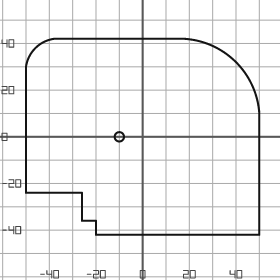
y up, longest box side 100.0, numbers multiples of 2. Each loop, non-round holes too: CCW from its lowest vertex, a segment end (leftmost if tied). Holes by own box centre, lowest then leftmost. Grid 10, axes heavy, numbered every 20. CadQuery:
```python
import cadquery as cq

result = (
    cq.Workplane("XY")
    .moveTo(-20.0, -42.0)
    .lineTo(50.0, -42.0)
    .lineTo(50.0, 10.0)
    .threePointArc((40.0, 32.0), (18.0, 42.0))
    .lineTo(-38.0, 42.0)
    .threePointArc((-46.0, 38.0), (-50.0, 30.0))
    .lineTo(-50.0, -24.0)
    .lineTo(-26.0, -24.0)
    .lineTo(-26.0, -36.0)
    .lineTo(-20.0, -36.0)
    .close()
    .moveTo(-10.0, 0.0)
    .circle(2.0)
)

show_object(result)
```